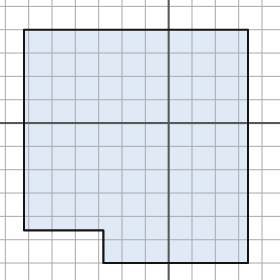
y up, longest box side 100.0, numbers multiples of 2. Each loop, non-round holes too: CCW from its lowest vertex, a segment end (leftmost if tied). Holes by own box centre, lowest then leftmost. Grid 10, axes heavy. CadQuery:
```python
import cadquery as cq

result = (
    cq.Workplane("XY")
    .moveTo(-28.0, -60.0)
    .lineTo(34.0, -60.0)
    .lineTo(34.0, 40.0)
    .lineTo(-62.0, 40.0)
    .lineTo(-62.0, -46.0)
    .lineTo(-28.0, -46.0)
    .close()
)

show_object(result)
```